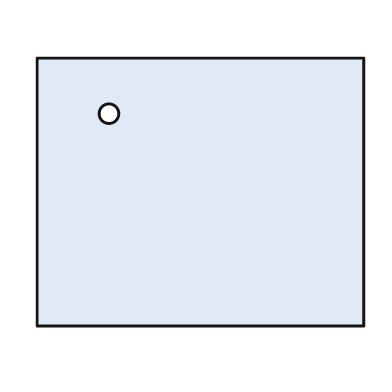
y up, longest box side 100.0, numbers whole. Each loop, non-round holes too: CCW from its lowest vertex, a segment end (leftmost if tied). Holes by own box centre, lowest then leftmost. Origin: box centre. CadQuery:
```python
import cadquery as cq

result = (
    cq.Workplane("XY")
    .moveTo(-50.0, -41.0)
    .lineTo(50.0, -41.0)
    .lineTo(50.0, 41.0)
    .lineTo(-50.0, 41.0)
    .close()
    .moveTo(-28.0, 24.0)
    .circle(3.0)
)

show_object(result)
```